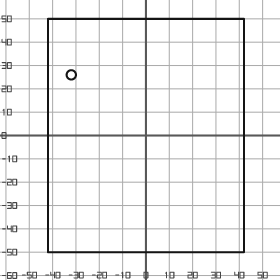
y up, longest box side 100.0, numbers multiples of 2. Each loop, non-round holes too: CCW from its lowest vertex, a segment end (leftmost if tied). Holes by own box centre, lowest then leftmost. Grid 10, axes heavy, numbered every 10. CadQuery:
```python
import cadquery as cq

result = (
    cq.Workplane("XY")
    .moveTo(-42.0, -50.0)
    .lineTo(42.0, -50.0)
    .lineTo(42.0, 50.0)
    .lineTo(-42.0, 50.0)
    .close()
    .moveTo(-32.0, 26.0)
    .circle(2.0)
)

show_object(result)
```